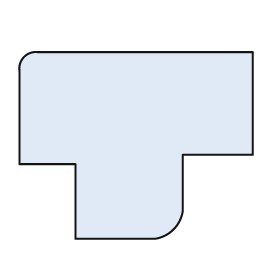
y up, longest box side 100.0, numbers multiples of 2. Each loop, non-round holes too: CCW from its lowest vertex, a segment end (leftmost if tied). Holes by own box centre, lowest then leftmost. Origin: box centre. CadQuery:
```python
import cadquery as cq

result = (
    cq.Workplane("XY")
    .moveTo(-26.0, -40.0)
    .lineTo(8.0, -40.0)
    .threePointArc((16.0, -36.0), (20.0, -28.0))
    .lineTo(20.0, -4.0)
    .lineTo(50.0, -4.0)
    .lineTo(50.0, 40.0)
    .lineTo(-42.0, 40.0)
    .threePointArc((-48.0, 38.0), (-50.0, 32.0))
    .lineTo(-50.0, -8.0)
    .lineTo(-26.0, -8.0)
    .close()
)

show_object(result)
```